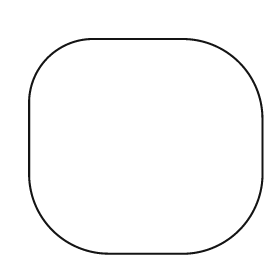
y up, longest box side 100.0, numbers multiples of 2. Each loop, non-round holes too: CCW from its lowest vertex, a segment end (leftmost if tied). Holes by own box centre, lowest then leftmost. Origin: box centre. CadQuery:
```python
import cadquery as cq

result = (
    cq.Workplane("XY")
    .moveTo(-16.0, -46.0)
    .lineTo(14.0, -46.0)
    .threePointArc((40.0, -36.0), (50.0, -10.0))
    .lineTo(50.0, 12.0)
    .threePointArc((40.0, 36.0), (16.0, 46.0))
    .lineTo(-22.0, 46.0)
    .threePointArc((-42.0, 38.0), (-50.0, 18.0))
    .lineTo(-50.0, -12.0)
    .threePointArc((-40.0, -36.0), (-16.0, -46.0))
    .close()
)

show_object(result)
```